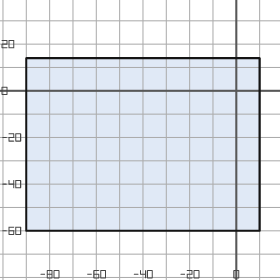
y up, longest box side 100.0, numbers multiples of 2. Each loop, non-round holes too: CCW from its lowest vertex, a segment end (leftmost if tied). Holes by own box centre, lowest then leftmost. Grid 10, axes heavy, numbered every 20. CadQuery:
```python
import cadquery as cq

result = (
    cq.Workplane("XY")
    .moveTo(-90.0, -60.0)
    .lineTo(10.0, -60.0)
    .lineTo(10.0, 14.0)
    .lineTo(-90.0, 14.0)
    .close()
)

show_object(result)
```